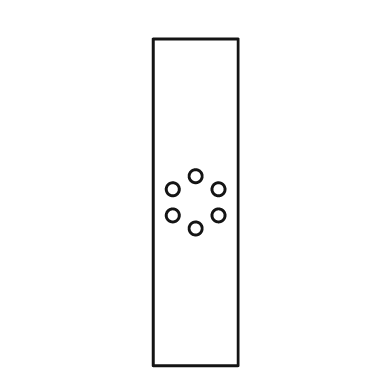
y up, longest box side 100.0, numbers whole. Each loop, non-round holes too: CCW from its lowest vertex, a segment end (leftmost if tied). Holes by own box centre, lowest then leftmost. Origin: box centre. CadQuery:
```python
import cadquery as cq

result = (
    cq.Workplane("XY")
    .moveTo(-13.0, -50.0)
    .lineTo(13.0, -50.0)
    .lineTo(13.0, 50.0)
    .lineTo(-13.0, 50.0)
    .close()
    .moveTo(0.0, -8.0)
    .circle(2.0)
    .moveTo(-7.0, -4.0)
    .circle(2.0)
    .moveTo(7.0, -4.0)
    .circle(2.0)
    .moveTo(-7.0, 4.0)
    .circle(2.0)
    .moveTo(7.0, 4.0)
    .circle(2.0)
    .moveTo(0.0, 8.0)
    .circle(2.0)
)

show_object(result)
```